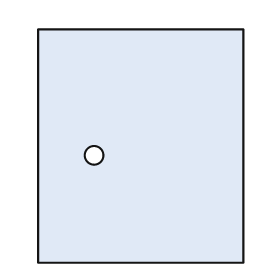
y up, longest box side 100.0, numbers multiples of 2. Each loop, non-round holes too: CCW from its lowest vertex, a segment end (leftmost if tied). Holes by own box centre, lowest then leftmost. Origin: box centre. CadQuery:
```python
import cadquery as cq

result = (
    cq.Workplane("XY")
    .moveTo(-44.0, -50.0)
    .lineTo(44.0, -50.0)
    .lineTo(44.0, 50.0)
    .lineTo(-44.0, 50.0)
    .close()
    .moveTo(-20.0, -4.0)
    .circle(4.0)
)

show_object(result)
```